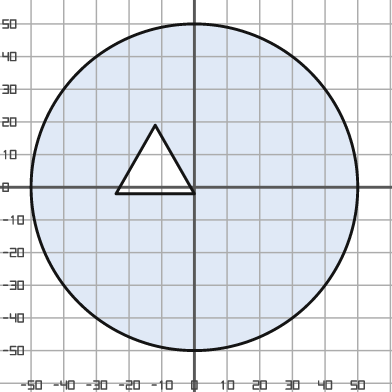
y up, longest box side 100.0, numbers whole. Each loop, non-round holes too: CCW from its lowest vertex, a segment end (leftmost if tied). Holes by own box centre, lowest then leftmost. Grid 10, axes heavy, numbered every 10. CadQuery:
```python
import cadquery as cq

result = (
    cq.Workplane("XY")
    .moveTo(0.0, 0.0)
    .circle(50.0)
    .moveTo(-24.0, -2.0)
    .lineTo(0.0, -2.0)
    .lineTo(-12.0, 19.0)
    .close()
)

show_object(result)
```